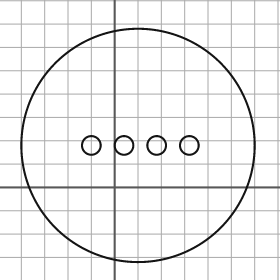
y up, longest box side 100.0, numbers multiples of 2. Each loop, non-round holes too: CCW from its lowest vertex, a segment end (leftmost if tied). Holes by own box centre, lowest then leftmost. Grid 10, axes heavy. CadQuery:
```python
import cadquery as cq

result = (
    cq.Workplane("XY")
    .moveTo(10.0, 18.0)
    .circle(50.0)
    .moveTo(-10.0, 18.0)
    .circle(4.0)
    .moveTo(4.0, 18.0)
    .circle(4.0)
    .moveTo(18.0, 18.0)
    .circle(4.0)
    .moveTo(32.0, 18.0)
    .circle(4.0)
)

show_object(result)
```